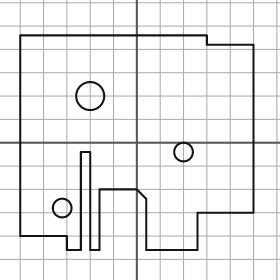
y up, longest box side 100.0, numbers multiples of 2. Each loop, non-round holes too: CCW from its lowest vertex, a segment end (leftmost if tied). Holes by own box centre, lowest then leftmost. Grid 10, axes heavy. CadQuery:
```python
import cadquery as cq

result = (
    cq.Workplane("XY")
    .moveTo(-30.0, -46.0)
    .lineTo(-24.0, -46.0)
    .lineTo(-24.0, -4.0)
    .lineTo(-20.0, -4.0)
    .lineTo(-20.0, -46.0)
    .lineTo(-16.0, -46.0)
    .lineTo(-16.0, -20.0)
    .lineTo(0.0, -20.0)
    .lineTo(4.0, -24.0)
    .lineTo(4.0, -46.0)
    .lineTo(26.0, -46.0)
    .lineTo(26.0, -30.0)
    .lineTo(50.0, -30.0)
    .lineTo(50.0, 42.0)
    .lineTo(30.0, 42.0)
    .lineTo(30.0, 46.0)
    .lineTo(-50.0, 46.0)
    .lineTo(-50.0, -40.0)
    .lineTo(-30.0, -40.0)
    .close()
    .moveTo(-32.0, -28.0)
    .circle(4.0)
    .moveTo(20.0, -4.0)
    .circle(4.0)
    .moveTo(-20.0, 20.0)
    .circle(6.0)
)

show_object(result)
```